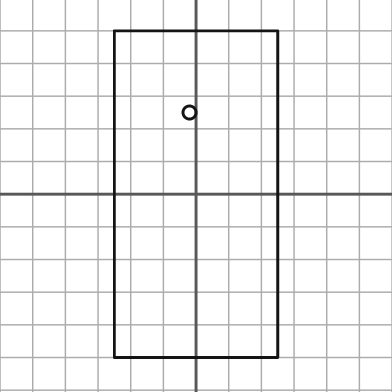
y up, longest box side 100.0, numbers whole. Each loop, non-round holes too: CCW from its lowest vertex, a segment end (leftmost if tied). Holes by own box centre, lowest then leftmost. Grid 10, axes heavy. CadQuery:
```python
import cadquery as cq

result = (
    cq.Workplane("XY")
    .moveTo(-25.0, -50.0)
    .lineTo(25.0, -50.0)
    .lineTo(25.0, 50.0)
    .lineTo(-25.0, 50.0)
    .close()
    .moveTo(-2.0, 25.0)
    .circle(2.0)
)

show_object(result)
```